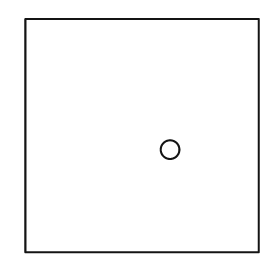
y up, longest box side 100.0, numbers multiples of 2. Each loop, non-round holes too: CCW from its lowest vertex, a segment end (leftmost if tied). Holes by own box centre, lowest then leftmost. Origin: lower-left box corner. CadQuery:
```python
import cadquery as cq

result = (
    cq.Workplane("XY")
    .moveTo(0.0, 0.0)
    .lineTo(100.0, 0.0)
    .lineTo(100.0, 100.0)
    .lineTo(0.0, 100.0)
    .close()
    .moveTo(62.0, 44.0)
    .circle(4.0)
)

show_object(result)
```